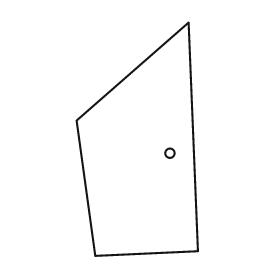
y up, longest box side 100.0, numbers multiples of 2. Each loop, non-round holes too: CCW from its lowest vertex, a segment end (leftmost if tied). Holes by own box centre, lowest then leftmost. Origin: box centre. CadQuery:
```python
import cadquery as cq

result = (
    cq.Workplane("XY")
    .moveTo(-18.0, -50.0)
    .lineTo(26.0, -48.0)
    .lineTo(22.0, 50.0)
    .lineTo(-26.0, 8.0)
    .close()
    .moveTo(14.0, -6.0)
    .circle(2.0)
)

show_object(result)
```